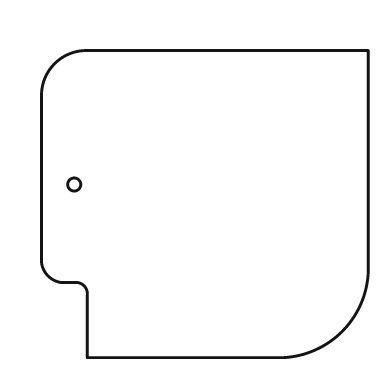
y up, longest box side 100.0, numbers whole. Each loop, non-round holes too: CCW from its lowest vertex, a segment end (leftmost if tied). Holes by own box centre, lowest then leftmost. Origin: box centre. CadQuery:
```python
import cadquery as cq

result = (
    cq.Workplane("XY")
    .moveTo(-36.0, -47.0)
    .lineTo(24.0, -47.0)
    .threePointArc((42.0, -39.0), (50.0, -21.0))
    .lineTo(50.0, 47.0)
    .lineTo(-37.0, 47.0)
    .threePointArc((-46.0, 43.0), (-50.0, 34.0))
    .lineTo(-50.0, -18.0)
    .threePointArc((-48.0, -22.0), (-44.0, -24.0))
    .lineTo(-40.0, -24.0)
    .threePointArc((-37.0, -25.0), (-36.0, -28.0))
    .close()
    .moveTo(-40.0, 6.0)
    .circle(2.0)
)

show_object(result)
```